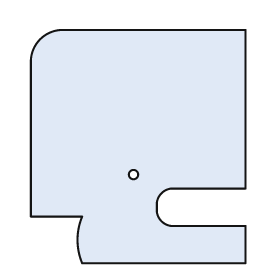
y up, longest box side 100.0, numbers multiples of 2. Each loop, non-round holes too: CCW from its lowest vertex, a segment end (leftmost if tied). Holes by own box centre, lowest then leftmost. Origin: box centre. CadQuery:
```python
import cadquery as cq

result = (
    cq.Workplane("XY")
    .moveTo(-24.0, -50.0)
    .lineTo(46.0, -50.0)
    .lineTo(46.0, -34.0)
    .lineTo(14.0, -34.0)
    .threePointArc((10.0, -32.0), (8.0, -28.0))
    .lineTo(8.0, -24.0)
    .threePointArc((10.0, -20.0), (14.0, -18.0))
    .lineTo(46.0, -18.0)
    .lineTo(46.0, 50.0)
    .lineTo(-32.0, 50.0)
    .threePointArc((-42.0, 46.0), (-46.0, 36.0))
    .lineTo(-46.0, -30.0)
    .lineTo(-24.0, -30.0)
    .threePointArc((-26.0, -40.0), (-24.0, -50.0))
    .close()
    .moveTo(-2.0, -12.0)
    .circle(2.0)
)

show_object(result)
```